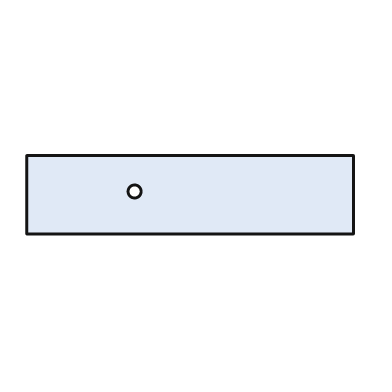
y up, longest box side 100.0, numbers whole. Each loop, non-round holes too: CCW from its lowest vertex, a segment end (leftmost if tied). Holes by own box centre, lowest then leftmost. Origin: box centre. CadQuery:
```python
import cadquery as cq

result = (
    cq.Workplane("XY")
    .moveTo(-50.0, -12.0)
    .lineTo(50.0, -12.0)
    .lineTo(50.0, 12.0)
    .lineTo(-50.0, 12.0)
    .close()
    .moveTo(-17.0, 1.0)
    .circle(2.0)
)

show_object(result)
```